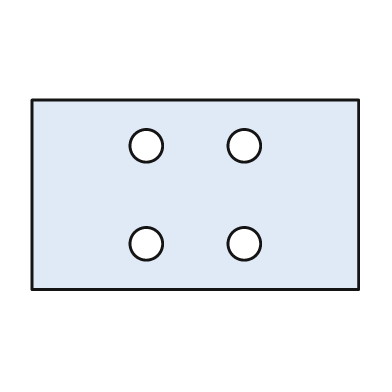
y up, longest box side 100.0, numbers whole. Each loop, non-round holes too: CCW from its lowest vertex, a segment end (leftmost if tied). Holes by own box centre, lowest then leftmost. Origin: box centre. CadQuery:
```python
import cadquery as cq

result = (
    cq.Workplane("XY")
    .moveTo(-50.0, -29.0)
    .lineTo(50.0, -29.0)
    .lineTo(50.0, 29.0)
    .lineTo(-50.0, 29.0)
    .close()
    .moveTo(-15.0, -15.0)
    .circle(5.0)
    .moveTo(15.0, -15.0)
    .circle(5.0)
    .moveTo(-15.0, 15.0)
    .circle(5.0)
    .moveTo(15.0, 15.0)
    .circle(5.0)
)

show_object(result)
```